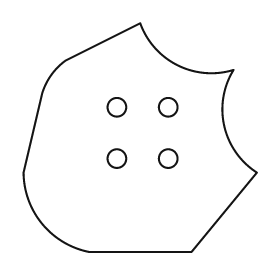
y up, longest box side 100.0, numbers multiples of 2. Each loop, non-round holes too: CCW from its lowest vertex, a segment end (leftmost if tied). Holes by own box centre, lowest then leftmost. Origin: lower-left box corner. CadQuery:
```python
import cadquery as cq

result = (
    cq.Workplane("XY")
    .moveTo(28.0, 0.0)
    .lineTo(72.0, 0.0)
    .lineTo(100.0, 34.0)
    .threePointArc((86.0, 54.0), (90.0, 78.0))
    .threePointArc((66.0, 80.0), (50.0, 98.0))
    .lineTo(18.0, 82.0)
    .threePointArc((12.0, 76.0), (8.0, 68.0))
    .lineTo(0.0, 34.0)
    .threePointArc((8.0, 12.0), (28.0, 0.0))
    .close()
    .moveTo(40.0, 40.0)
    .circle(4.0)
    .moveTo(62.0, 40.0)
    .circle(4.0)
    .moveTo(40.0, 62.0)
    .circle(4.0)
    .moveTo(62.0, 62.0)
    .circle(4.0)
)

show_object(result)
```